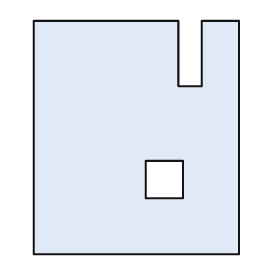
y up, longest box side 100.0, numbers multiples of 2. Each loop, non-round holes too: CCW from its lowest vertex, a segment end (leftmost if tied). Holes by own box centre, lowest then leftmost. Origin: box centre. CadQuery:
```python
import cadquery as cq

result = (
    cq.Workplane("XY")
    .moveTo(-44.0, -50.0)
    .lineTo(44.0, -50.0)
    .lineTo(44.0, 50.0)
    .lineTo(28.0, 50.0)
    .lineTo(28.0, 22.0)
    .lineTo(18.0, 22.0)
    .lineTo(18.0, 50.0)
    .lineTo(-44.0, 50.0)
    .close()
    .moveTo(4.0, -26.0)
    .lineTo(20.0, -26.0)
    .lineTo(20.0, -10.0)
    .lineTo(4.0, -10.0)
    .close()
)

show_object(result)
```